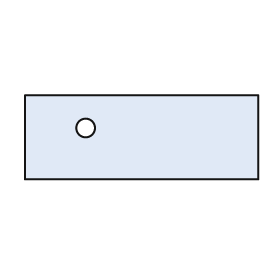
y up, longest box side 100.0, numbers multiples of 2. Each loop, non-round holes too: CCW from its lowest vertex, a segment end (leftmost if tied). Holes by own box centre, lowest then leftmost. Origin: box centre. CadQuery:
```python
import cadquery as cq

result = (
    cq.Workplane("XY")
    .moveTo(-50.0, -18.0)
    .lineTo(50.0, -18.0)
    .lineTo(50.0, 18.0)
    .lineTo(-50.0, 18.0)
    .close()
    .moveTo(-24.0, 4.0)
    .circle(4.0)
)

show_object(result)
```